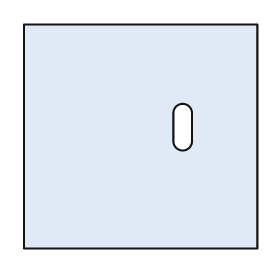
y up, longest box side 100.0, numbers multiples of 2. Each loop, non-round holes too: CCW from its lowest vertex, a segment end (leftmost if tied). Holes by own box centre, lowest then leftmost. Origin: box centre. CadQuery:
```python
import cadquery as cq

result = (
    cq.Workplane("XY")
    .moveTo(-50.0, -48.0)
    .lineTo(50.0, -48.0)
    .lineTo(50.0, 48.0)
    .lineTo(-50.0, 48.0)
    .close()
    .moveTo(14.0, -2.0)
    .threePointArc((18.0, -6.0), (22.0, -2.0))
    .lineTo(22.0, 10.0)
    .threePointArc((18.0, 14.0), (14.0, 10.0))
    .close()
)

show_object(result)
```